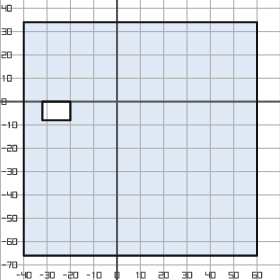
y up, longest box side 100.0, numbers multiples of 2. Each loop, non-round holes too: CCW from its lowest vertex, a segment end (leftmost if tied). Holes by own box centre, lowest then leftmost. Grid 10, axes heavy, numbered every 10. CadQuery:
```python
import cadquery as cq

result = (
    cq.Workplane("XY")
    .moveTo(-40.0, -66.0)
    .lineTo(60.0, -66.0)
    .lineTo(60.0, 34.0)
    .lineTo(-40.0, 34.0)
    .close()
    .moveTo(-32.0, -8.0)
    .lineTo(-20.0, -8.0)
    .lineTo(-20.0, 0.0)
    .lineTo(-32.0, 0.0)
    .close()
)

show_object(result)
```